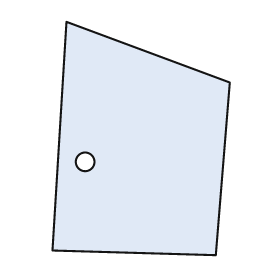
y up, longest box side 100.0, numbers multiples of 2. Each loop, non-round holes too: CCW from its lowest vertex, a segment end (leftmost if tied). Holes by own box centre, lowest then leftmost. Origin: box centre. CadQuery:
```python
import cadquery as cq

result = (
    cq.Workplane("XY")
    .moveTo(32.0, -50.0)
    .lineTo(38.0, 24.0)
    .lineTo(-32.0, 50.0)
    .lineTo(-38.0, -48.0)
    .close()
    .moveTo(-24.0, -10.0)
    .circle(4.0)
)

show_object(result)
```